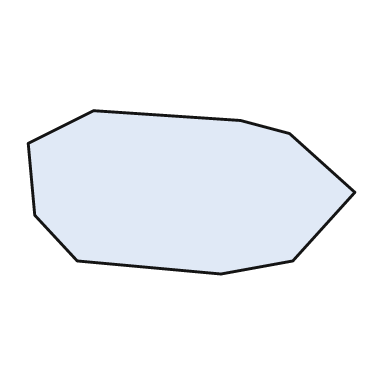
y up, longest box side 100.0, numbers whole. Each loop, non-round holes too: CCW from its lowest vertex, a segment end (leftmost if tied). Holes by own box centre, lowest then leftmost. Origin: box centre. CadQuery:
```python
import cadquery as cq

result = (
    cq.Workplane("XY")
    .moveTo(9.0, -25.0)
    .lineTo(31.0, -21.0)
    .lineTo(50.0, 0.0)
    .lineTo(30.0, 18.0)
    .lineTo(15.0, 22.0)
    .lineTo(-30.0, 25.0)
    .lineTo(-50.0, 15.0)
    .lineTo(-48.0, -7.0)
    .lineTo(-35.0, -21.0)
    .close()
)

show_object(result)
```